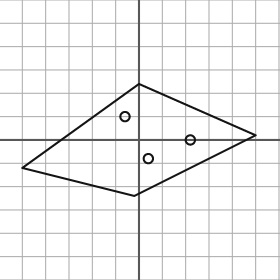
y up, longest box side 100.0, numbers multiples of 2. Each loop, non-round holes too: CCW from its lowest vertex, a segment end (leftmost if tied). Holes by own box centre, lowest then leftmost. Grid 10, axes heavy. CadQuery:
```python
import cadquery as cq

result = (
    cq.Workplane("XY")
    .moveTo(-2.0, -24.0)
    .lineTo(50.0, 2.0)
    .lineTo(0.0, 24.0)
    .lineTo(-50.0, -12.0)
    .close()
    .moveTo(4.0, -8.0)
    .circle(2.0)
    .moveTo(22.0, 0.0)
    .circle(2.0)
    .moveTo(-6.0, 10.0)
    .circle(2.0)
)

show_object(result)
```